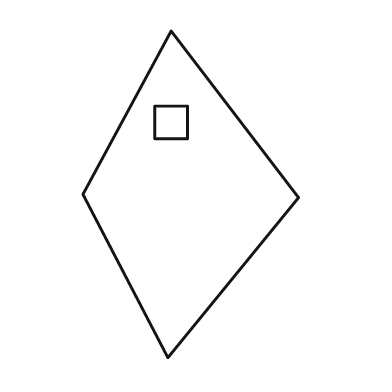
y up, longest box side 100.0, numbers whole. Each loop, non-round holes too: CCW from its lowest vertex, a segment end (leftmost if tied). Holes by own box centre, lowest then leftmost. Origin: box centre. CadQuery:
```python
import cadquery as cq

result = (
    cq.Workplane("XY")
    .moveTo(-7.0, -50.0)
    .lineTo(33.0, -1.0)
    .lineTo(-6.0, 50.0)
    .lineTo(-33.0, 0.0)
    .close()
    .moveTo(-11.0, 17.0)
    .lineTo(-1.0, 17.0)
    .lineTo(-1.0, 27.0)
    .lineTo(-11.0, 27.0)
    .close()
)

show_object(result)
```